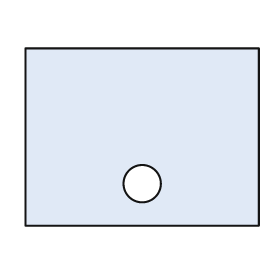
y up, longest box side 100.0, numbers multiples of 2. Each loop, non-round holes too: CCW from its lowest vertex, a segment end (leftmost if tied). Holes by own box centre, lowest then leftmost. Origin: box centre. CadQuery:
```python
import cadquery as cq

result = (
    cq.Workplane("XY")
    .moveTo(-50.0, -38.0)
    .lineTo(50.0, -38.0)
    .lineTo(50.0, 38.0)
    .lineTo(-50.0, 38.0)
    .close()
    .moveTo(0.0, -20.0)
    .circle(8.0)
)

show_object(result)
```